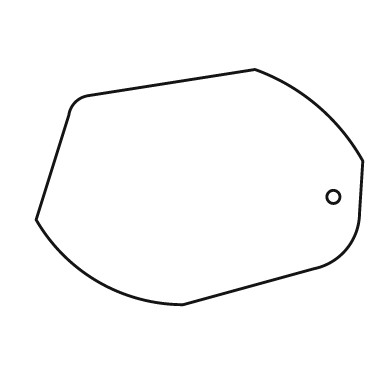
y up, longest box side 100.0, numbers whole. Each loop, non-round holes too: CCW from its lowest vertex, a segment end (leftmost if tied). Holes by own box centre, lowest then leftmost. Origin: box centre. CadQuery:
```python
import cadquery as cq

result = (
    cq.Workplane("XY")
    .moveTo(-5.0, -36.0)
    .lineTo(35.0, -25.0)
    .threePointArc((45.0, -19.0), (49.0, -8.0))
    .lineTo(50.0, 8.0)
    .threePointArc((36.0, 25.0), (17.0, 36.0))
    .lineTo(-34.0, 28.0)
    .threePointArc((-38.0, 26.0), (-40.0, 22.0))
    .lineTo(-50.0, -10.0)
    .threePointArc((-31.0, -29.0), (-5.0, -36.0))
    .close()
    .moveTo(41.0, -3.0)
    .circle(2.0)
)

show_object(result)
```